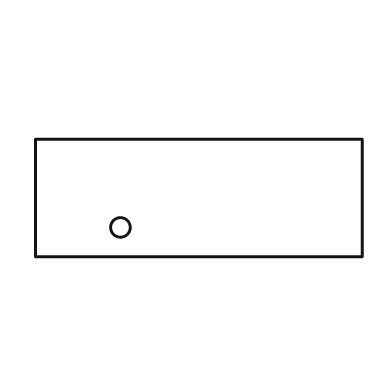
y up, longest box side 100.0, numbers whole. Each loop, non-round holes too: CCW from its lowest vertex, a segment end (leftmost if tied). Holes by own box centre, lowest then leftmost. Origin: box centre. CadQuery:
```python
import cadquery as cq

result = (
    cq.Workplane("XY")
    .moveTo(-50.0, -18.0)
    .lineTo(50.0, -18.0)
    .lineTo(50.0, 18.0)
    .lineTo(-50.0, 18.0)
    .close()
    .moveTo(-24.0, -9.0)
    .circle(3.0)
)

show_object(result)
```